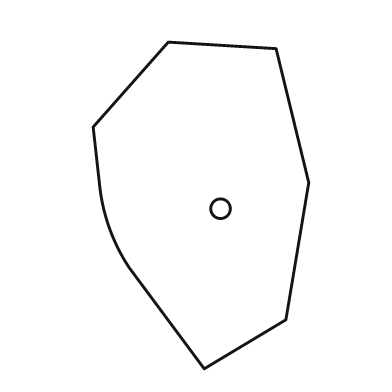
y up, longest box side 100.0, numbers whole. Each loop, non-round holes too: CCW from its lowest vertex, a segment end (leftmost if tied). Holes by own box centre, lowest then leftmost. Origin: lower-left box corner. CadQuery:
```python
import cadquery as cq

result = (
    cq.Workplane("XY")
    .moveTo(34.0, 0.0)
    .lineTo(59.0, 15.0)
    .lineTo(66.0, 57.0)
    .lineTo(56.0, 98.0)
    .lineTo(23.0, 100.0)
    .lineTo(0.0, 74.0)
    .lineTo(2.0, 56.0)
    .threePointArc((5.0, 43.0), (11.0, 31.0))
    .close()
    .moveTo(39.0, 49.0)
    .circle(3.0)
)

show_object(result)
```